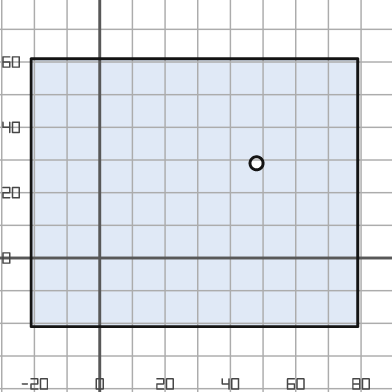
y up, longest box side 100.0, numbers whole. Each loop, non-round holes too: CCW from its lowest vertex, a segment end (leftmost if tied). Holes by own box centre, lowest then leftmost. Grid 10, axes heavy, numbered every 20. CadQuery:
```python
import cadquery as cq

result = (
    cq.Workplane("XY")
    .moveTo(-21.0, -21.0)
    .lineTo(79.0, -21.0)
    .lineTo(79.0, 61.0)
    .lineTo(-21.0, 61.0)
    .close()
    .moveTo(48.0, 29.0)
    .circle(2.0)
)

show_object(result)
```